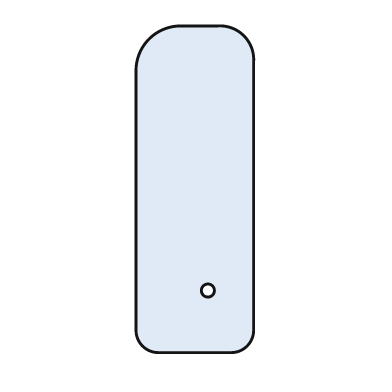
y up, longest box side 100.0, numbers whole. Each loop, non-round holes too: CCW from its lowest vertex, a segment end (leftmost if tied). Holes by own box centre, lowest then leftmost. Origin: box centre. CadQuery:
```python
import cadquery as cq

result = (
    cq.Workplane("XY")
    .moveTo(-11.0, -50.0)
    .lineTo(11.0, -50.0)
    .threePointArc((16.0, -48.0), (18.0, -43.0))
    .lineTo(18.0, 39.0)
    .threePointArc((15.0, 47.0), (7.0, 50.0))
    .lineTo(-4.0, 50.0)
    .threePointArc((-14.0, 46.0), (-18.0, 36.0))
    .lineTo(-18.0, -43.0)
    .threePointArc((-16.0, -48.0), (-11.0, -50.0))
    .close()
    .moveTo(4.0, -31.0)
    .circle(2.0)
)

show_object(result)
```